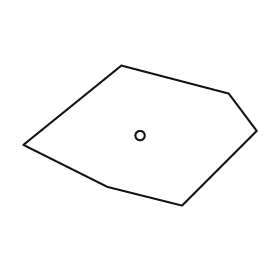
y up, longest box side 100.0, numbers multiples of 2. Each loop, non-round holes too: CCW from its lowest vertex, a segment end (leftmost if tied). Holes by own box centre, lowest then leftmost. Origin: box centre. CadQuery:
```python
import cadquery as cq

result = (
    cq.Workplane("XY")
    .moveTo(18.0, -30.0)
    .lineTo(50.0, 2.0)
    .lineTo(38.0, 18.0)
    .lineTo(-8.0, 30.0)
    .lineTo(-50.0, -4.0)
    .lineTo(-14.0, -22.0)
    .close()
    .moveTo(0.0, 0.0)
    .circle(2.0)
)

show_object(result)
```